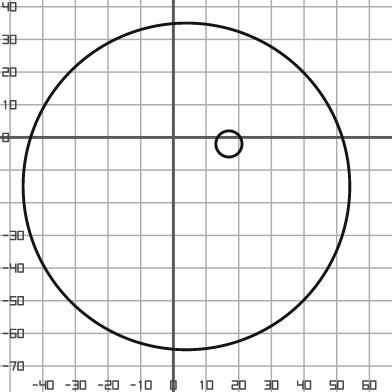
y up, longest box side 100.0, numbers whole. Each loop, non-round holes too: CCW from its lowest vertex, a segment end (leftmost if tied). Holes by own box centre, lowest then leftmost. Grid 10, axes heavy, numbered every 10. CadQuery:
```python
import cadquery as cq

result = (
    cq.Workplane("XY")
    .moveTo(4.0, -15.0)
    .circle(50.0)
    .moveTo(17.0, -2.0)
    .circle(4.0)
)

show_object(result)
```